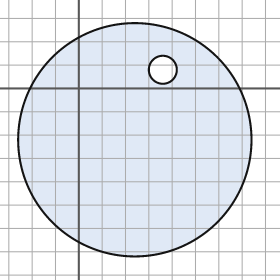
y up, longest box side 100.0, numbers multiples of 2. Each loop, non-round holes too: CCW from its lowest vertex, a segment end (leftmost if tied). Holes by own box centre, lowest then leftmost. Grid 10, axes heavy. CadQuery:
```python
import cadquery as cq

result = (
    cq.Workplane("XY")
    .moveTo(24.0, -22.0)
    .circle(50.0)
    .moveTo(36.0, 8.0)
    .circle(6.0)
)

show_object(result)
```